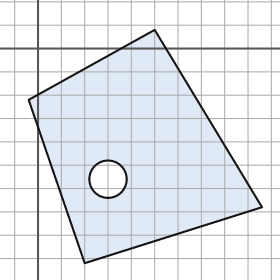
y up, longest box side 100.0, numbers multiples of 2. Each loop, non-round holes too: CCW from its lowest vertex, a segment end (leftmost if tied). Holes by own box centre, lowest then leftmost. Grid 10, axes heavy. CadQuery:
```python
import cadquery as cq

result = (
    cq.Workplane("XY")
    .moveTo(20.0, -92.0)
    .lineTo(96.0, -68.0)
    .lineTo(50.0, 8.0)
    .lineTo(-4.0, -22.0)
    .close()
    .moveTo(30.0, -56.0)
    .circle(8.0)
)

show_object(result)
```